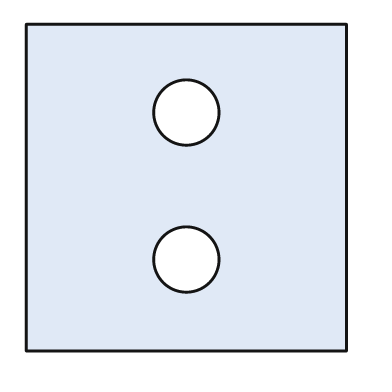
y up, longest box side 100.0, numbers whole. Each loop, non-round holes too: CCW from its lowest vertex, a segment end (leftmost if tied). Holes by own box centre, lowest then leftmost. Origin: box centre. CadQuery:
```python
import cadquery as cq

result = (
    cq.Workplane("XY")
    .moveTo(-49.0, -50.0)
    .lineTo(49.0, -50.0)
    .lineTo(49.0, 50.0)
    .lineTo(-49.0, 50.0)
    .close()
    .moveTo(0.0, -22.0)
    .circle(10.0)
    .moveTo(0.0, 23.0)
    .circle(10.0)
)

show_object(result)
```